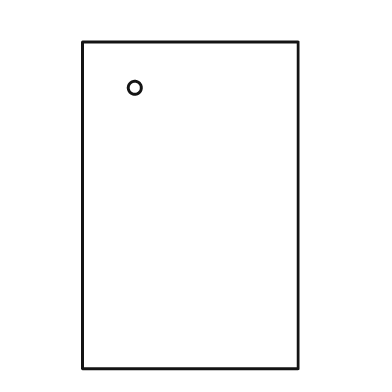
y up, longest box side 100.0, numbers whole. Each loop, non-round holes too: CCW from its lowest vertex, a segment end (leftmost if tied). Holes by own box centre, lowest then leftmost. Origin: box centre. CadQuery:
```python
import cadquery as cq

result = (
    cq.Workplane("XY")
    .moveTo(-33.0, -50.0)
    .lineTo(33.0, -50.0)
    .lineTo(33.0, 50.0)
    .lineTo(-33.0, 50.0)
    .close()
    .moveTo(-17.0, 36.0)
    .circle(2.0)
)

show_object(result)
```